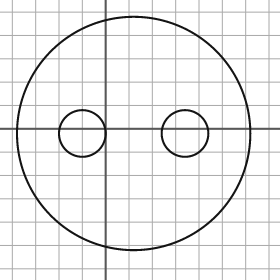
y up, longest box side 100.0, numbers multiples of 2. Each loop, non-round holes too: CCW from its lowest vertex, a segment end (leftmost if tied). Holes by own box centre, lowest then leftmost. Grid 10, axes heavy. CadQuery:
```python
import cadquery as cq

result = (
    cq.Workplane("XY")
    .moveTo(12.0, -2.0)
    .circle(50.0)
    .moveTo(-10.0, -2.0)
    .circle(10.0)
    .moveTo(34.0, -2.0)
    .circle(10.0)
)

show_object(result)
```